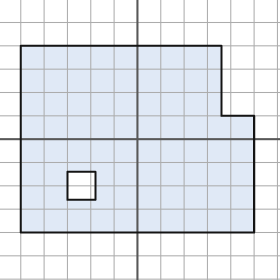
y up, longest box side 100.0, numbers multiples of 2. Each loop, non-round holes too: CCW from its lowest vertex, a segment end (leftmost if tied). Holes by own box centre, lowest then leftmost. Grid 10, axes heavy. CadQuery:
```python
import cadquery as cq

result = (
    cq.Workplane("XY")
    .moveTo(-50.0, -40.0)
    .lineTo(50.0, -40.0)
    .lineTo(50.0, 10.0)
    .lineTo(36.0, 10.0)
    .lineTo(36.0, 40.0)
    .lineTo(-50.0, 40.0)
    .close()
    .moveTo(-30.0, -26.0)
    .lineTo(-18.0, -26.0)
    .lineTo(-18.0, -14.0)
    .lineTo(-30.0, -14.0)
    .close()
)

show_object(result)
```